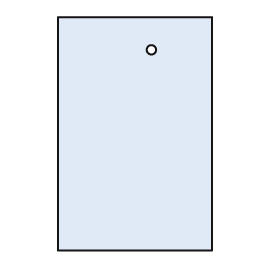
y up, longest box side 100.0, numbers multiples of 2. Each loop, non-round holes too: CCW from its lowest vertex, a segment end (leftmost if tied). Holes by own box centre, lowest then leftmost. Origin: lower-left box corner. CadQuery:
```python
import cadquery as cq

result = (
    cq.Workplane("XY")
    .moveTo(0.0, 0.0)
    .lineTo(66.0, 0.0)
    .lineTo(66.0, 100.0)
    .lineTo(0.0, 100.0)
    .close()
    .moveTo(40.0, 86.0)
    .circle(2.0)
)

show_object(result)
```